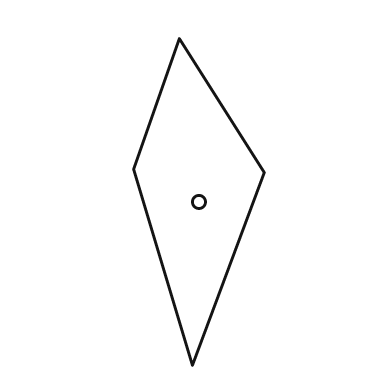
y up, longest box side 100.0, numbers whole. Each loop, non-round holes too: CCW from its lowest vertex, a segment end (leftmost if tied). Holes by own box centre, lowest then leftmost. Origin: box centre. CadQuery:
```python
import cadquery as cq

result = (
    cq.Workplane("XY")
    .moveTo(-2.0, -50.0)
    .lineTo(20.0, 9.0)
    .lineTo(-6.0, 50.0)
    .lineTo(-20.0, 10.0)
    .close()
    .moveTo(0.0, 0.0)
    .circle(2.0)
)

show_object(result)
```